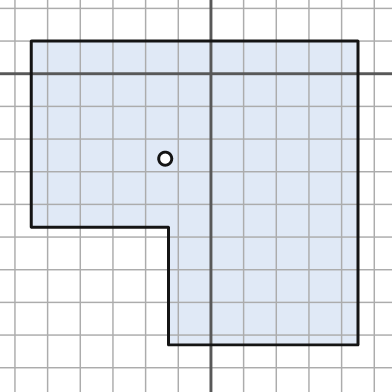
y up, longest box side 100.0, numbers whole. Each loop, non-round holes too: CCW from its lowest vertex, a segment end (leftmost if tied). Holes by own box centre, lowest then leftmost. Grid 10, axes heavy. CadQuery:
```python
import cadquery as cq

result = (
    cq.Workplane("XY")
    .moveTo(-13.0, -83.0)
    .lineTo(45.0, -83.0)
    .lineTo(45.0, 10.0)
    .lineTo(-55.0, 10.0)
    .lineTo(-55.0, -47.0)
    .lineTo(-13.0, -47.0)
    .close()
    .moveTo(-14.0, -26.0)
    .circle(2.0)
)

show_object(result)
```